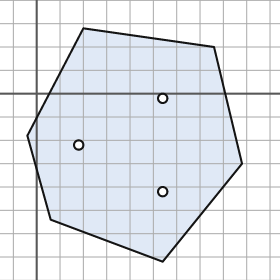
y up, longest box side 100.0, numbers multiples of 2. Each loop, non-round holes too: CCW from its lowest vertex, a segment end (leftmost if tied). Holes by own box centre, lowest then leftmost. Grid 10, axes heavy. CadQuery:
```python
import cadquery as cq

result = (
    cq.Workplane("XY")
    .moveTo(54.0, -72.0)
    .lineTo(88.0, -30.0)
    .lineTo(76.0, 20.0)
    .lineTo(20.0, 28.0)
    .lineTo(-4.0, -18.0)
    .lineTo(6.0, -54.0)
    .close()
    .moveTo(54.0, -42.0)
    .circle(2.0)
    .moveTo(18.0, -22.0)
    .circle(2.0)
    .moveTo(54.0, -2.0)
    .circle(2.0)
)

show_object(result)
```